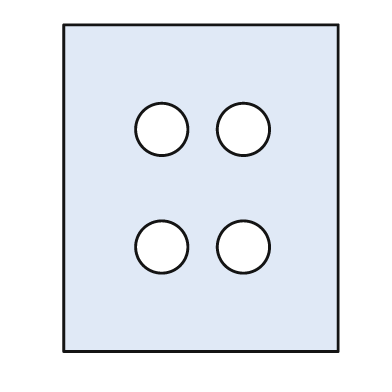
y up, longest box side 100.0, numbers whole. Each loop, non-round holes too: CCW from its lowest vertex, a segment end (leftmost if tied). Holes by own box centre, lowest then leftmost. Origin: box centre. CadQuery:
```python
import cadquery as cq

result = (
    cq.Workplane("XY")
    .moveTo(-42.0, -50.0)
    .lineTo(42.0, -50.0)
    .lineTo(42.0, 50.0)
    .lineTo(-42.0, 50.0)
    .close()
    .moveTo(-12.0, -18.0)
    .circle(8.0)
    .moveTo(13.0, -18.0)
    .circle(8.0)
    .moveTo(-12.0, 18.0)
    .circle(8.0)
    .moveTo(13.0, 18.0)
    .circle(8.0)
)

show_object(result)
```